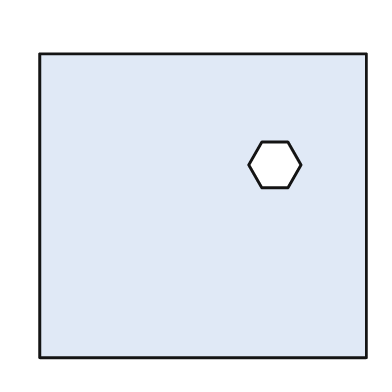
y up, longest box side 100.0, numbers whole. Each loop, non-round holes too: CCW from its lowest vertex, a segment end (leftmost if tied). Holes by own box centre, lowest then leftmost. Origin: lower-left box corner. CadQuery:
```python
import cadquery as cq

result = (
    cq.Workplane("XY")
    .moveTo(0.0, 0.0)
    .lineTo(100.0, 0.0)
    .lineTo(100.0, 93.0)
    .lineTo(0.0, 93.0)
    .close()
    .moveTo(68.0, 52.0)
    .lineTo(76.0, 52.0)
    .lineTo(80.0, 59.0)
    .lineTo(76.0, 66.0)
    .lineTo(68.0, 66.0)
    .lineTo(64.0, 59.0)
    .close()
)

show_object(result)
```